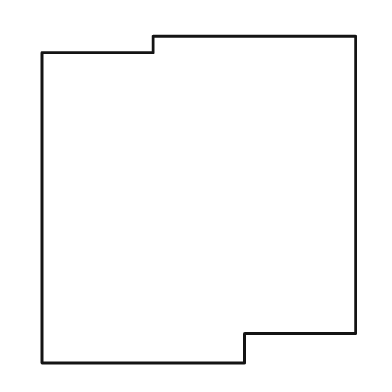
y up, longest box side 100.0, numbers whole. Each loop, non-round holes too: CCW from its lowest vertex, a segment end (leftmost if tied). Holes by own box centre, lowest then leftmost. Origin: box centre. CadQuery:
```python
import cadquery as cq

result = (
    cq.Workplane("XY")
    .moveTo(-48.0, -50.0)
    .lineTo(14.0, -50.0)
    .lineTo(14.0, -41.0)
    .lineTo(48.0, -41.0)
    .lineTo(48.0, 50.0)
    .lineTo(-14.0, 50.0)
    .lineTo(-14.0, 45.0)
    .lineTo(-48.0, 45.0)
    .close()
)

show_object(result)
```